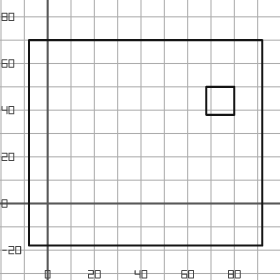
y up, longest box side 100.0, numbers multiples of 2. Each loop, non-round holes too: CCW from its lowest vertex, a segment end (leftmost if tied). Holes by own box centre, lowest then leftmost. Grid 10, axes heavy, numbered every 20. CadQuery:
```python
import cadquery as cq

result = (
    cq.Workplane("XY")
    .moveTo(-8.0, -18.0)
    .lineTo(92.0, -18.0)
    .lineTo(92.0, 70.0)
    .lineTo(-8.0, 70.0)
    .close()
    .moveTo(68.0, 38.0)
    .lineTo(80.0, 38.0)
    .lineTo(80.0, 50.0)
    .lineTo(68.0, 50.0)
    .close()
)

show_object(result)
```